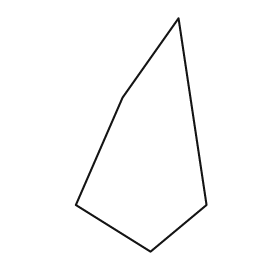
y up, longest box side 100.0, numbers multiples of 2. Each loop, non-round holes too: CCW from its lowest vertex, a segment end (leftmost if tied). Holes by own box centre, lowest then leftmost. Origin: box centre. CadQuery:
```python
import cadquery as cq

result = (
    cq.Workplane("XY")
    .moveTo(4.0, -50.0)
    .lineTo(28.0, -30.0)
    .lineTo(16.0, 50.0)
    .lineTo(-8.0, 16.0)
    .lineTo(-28.0, -30.0)
    .close()
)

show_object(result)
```